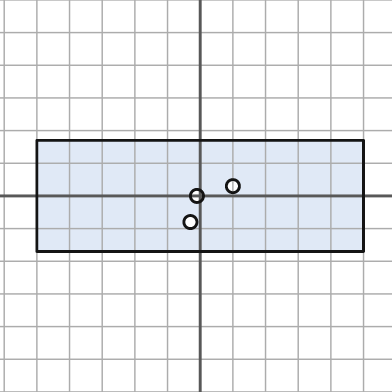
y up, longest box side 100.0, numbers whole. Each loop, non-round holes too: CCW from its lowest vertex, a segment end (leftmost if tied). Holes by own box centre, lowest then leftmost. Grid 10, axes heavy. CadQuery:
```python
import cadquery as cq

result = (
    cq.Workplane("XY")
    .moveTo(-50.0, -17.0)
    .lineTo(50.0, -17.0)
    .lineTo(50.0, 17.0)
    .lineTo(-50.0, 17.0)
    .close()
    .moveTo(-3.0, -8.0)
    .circle(2.0)
    .moveTo(-1.0, 0.0)
    .circle(2.0)
    .moveTo(10.0, 3.0)
    .circle(2.0)
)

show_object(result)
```